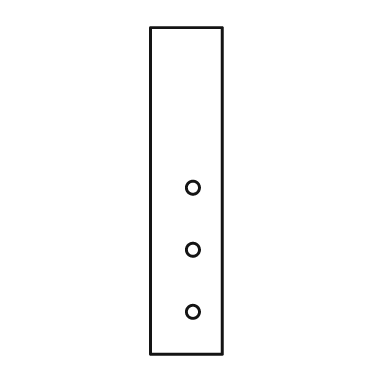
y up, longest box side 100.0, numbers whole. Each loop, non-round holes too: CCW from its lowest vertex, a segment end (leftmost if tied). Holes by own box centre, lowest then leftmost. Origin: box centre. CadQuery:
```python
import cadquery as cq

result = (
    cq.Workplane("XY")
    .moveTo(-11.0, -50.0)
    .lineTo(11.0, -50.0)
    .lineTo(11.0, 50.0)
    .lineTo(-11.0, 50.0)
    .close()
    .moveTo(2.0, -37.0)
    .circle(2.0)
    .moveTo(2.0, -18.0)
    .circle(2.0)
    .moveTo(2.0, 1.0)
    .circle(2.0)
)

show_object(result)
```